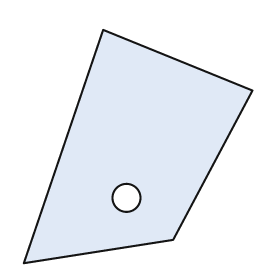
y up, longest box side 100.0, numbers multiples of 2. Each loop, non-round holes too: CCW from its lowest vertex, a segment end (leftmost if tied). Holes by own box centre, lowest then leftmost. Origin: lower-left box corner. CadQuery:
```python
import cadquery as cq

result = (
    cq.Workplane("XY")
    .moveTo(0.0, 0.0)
    .lineTo(64.0, 10.0)
    .lineTo(98.0, 74.0)
    .lineTo(34.0, 100.0)
    .close()
    .moveTo(44.0, 28.0)
    .circle(6.0)
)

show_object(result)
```